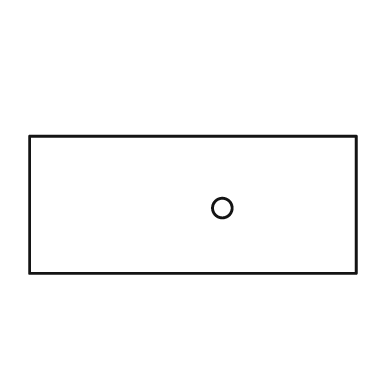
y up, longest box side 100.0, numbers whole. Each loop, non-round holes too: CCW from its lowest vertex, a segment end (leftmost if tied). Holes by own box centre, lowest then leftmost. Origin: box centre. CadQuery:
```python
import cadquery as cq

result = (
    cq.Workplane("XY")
    .moveTo(-50.0, -21.0)
    .lineTo(50.0, -21.0)
    .lineTo(50.0, 21.0)
    .lineTo(-50.0, 21.0)
    .close()
    .moveTo(9.0, -1.0)
    .circle(3.0)
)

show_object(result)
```